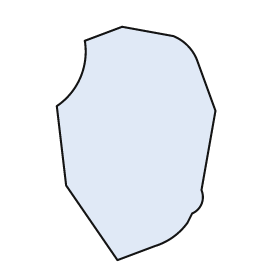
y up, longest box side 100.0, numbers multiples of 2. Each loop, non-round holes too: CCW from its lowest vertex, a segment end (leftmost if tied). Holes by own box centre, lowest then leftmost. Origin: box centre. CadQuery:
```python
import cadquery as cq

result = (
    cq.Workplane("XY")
    .moveTo(-8.0, -50.0)
    .lineTo(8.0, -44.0)
    .threePointArc((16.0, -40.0), (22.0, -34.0))
    .lineTo(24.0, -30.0)
    .threePointArc((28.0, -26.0), (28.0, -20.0))
    .lineTo(34.0, 14.0)
    .lineTo(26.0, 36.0)
    .threePointArc((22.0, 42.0), (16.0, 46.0))
    .lineTo(-6.0, 50.0)
    .lineTo(-22.0, 44.0)
    .threePointArc((-24.0, 28.0), (-34.0, 16.0))
    .lineTo(-30.0, -18.0)
    .close()
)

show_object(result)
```